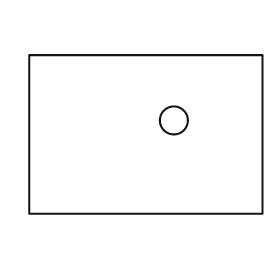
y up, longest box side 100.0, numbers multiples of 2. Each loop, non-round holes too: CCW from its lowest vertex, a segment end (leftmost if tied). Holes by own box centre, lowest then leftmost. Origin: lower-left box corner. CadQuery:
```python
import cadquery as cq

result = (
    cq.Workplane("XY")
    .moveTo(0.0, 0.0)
    .lineTo(100.0, 0.0)
    .lineTo(100.0, 68.0)
    .lineTo(0.0, 68.0)
    .close()
    .moveTo(62.0, 40.0)
    .circle(6.0)
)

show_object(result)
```